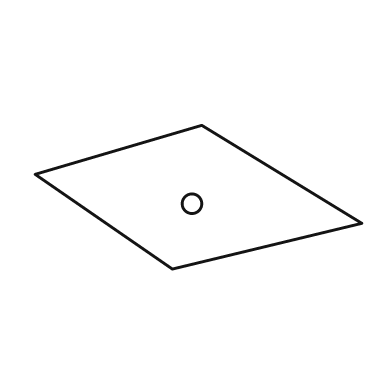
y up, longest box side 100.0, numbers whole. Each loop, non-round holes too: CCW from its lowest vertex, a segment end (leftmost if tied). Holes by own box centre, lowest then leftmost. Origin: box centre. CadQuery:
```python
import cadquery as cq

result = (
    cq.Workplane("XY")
    .moveTo(-8.0, -22.0)
    .lineTo(50.0, -8.0)
    .lineTo(1.0, 22.0)
    .lineTo(-50.0, 7.0)
    .close()
    .moveTo(-2.0, -2.0)
    .circle(3.0)
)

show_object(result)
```